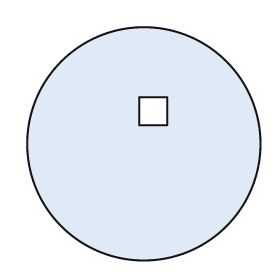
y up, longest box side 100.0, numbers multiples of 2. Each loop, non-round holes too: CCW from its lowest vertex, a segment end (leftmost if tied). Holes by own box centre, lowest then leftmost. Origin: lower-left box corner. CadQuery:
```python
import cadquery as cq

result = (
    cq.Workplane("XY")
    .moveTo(50.0, 50.0)
    .circle(50.0)
    .moveTo(48.0, 58.0)
    .lineTo(60.0, 58.0)
    .lineTo(60.0, 70.0)
    .lineTo(48.0, 70.0)
    .close()
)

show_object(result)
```